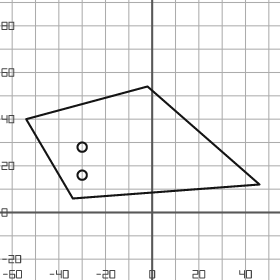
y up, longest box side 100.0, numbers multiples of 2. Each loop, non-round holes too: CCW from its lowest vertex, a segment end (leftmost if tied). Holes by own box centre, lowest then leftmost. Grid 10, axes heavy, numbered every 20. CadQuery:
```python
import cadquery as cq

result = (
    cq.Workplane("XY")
    .moveTo(-34.0, 6.0)
    .lineTo(46.0, 12.0)
    .lineTo(-2.0, 54.0)
    .lineTo(-54.0, 40.0)
    .close()
    .moveTo(-30.0, 16.0)
    .circle(2.0)
    .moveTo(-30.0, 28.0)
    .circle(2.0)
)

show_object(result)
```